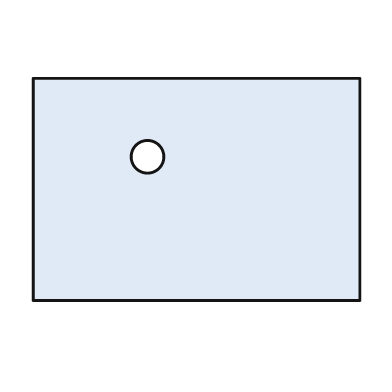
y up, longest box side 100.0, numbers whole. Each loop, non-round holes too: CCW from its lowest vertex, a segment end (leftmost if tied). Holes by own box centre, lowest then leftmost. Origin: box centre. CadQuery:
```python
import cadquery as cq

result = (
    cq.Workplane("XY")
    .moveTo(-50.0, -34.0)
    .lineTo(50.0, -34.0)
    .lineTo(50.0, 34.0)
    .lineTo(-50.0, 34.0)
    .close()
    .moveTo(-15.0, 10.0)
    .circle(5.0)
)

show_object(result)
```